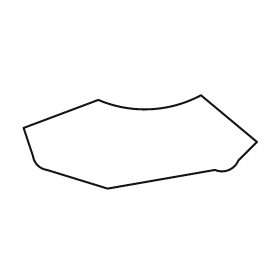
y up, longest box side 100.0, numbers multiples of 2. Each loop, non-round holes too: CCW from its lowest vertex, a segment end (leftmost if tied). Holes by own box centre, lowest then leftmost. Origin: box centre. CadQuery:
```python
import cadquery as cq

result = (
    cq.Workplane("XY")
    .moveTo(-14.0, -20.0)
    .lineTo(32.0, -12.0)
    .threePointArc((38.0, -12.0), (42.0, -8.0))
    .lineTo(50.0, 0.0)
    .lineTo(26.0, 20.0)
    .threePointArc((4.0, 14.0), (-18.0, 18.0))
    .lineTo(-50.0, 6.0)
    .lineTo(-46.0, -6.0)
    .threePointArc((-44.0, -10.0), (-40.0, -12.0))
    .close()
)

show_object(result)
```